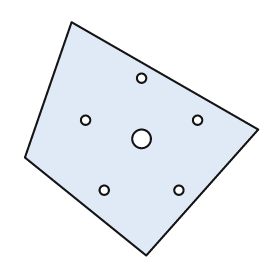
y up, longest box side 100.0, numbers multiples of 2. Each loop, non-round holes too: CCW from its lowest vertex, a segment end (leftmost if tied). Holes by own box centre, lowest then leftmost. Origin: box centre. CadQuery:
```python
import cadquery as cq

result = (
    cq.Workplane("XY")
    .moveTo(2.0, -50.0)
    .lineTo(50.0, 4.0)
    .lineTo(-30.0, 50.0)
    .lineTo(-50.0, -8.0)
    .close()
    .moveTo(-16.0, -22.0)
    .circle(2.0)
    .moveTo(16.0, -22.0)
    .circle(2.0)
    .moveTo(0.0, 0.0)
    .circle(4.0)
    .moveTo(-24.0, 8.0)
    .circle(2.0)
    .moveTo(24.0, 8.0)
    .circle(2.0)
    .moveTo(0.0, 26.0)
    .circle(2.0)
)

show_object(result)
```